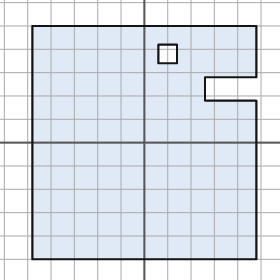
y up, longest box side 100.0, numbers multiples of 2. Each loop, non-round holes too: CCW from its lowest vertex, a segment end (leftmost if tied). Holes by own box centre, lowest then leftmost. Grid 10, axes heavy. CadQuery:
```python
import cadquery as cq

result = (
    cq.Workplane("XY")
    .moveTo(-48.0, -50.0)
    .lineTo(48.0, -50.0)
    .lineTo(48.0, 18.0)
    .lineTo(26.0, 18.0)
    .lineTo(26.0, 28.0)
    .lineTo(48.0, 28.0)
    .lineTo(48.0, 50.0)
    .lineTo(-48.0, 50.0)
    .close()
    .moveTo(6.0, 34.0)
    .lineTo(14.0, 34.0)
    .lineTo(14.0, 42.0)
    .lineTo(6.0, 42.0)
    .close()
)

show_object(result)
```